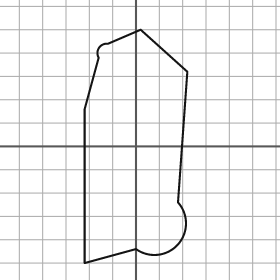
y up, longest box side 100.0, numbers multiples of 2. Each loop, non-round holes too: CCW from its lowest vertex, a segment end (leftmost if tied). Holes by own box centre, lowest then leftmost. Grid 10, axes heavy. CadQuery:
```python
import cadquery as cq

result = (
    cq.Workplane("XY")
    .moveTo(-22.0, -50.0)
    .lineTo(0.0, -44.0)
    .threePointArc((18.0, -42.0), (18.0, -24.0))
    .lineTo(22.0, 32.0)
    .lineTo(2.0, 50.0)
    .lineTo(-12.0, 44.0)
    .threePointArc((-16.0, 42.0), (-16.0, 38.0))
    .lineTo(-22.0, 16.0)
    .close()
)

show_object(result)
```